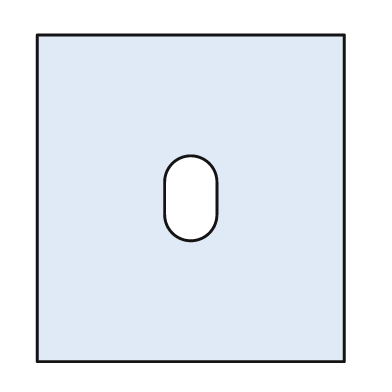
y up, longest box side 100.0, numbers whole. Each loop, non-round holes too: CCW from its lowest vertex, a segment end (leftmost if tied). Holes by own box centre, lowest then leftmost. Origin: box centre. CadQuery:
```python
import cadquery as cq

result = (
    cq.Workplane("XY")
    .moveTo(-47.0, -50.0)
    .lineTo(47.0, -50.0)
    .lineTo(47.0, 50.0)
    .lineTo(-47.0, 50.0)
    .close()
    .moveTo(-8.0, -5.0)
    .threePointArc((0.0, -13.0), (8.0, -5.0))
    .lineTo(8.0, 5.0)
    .threePointArc((0.0, 13.0), (-8.0, 5.0))
    .close()
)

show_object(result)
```